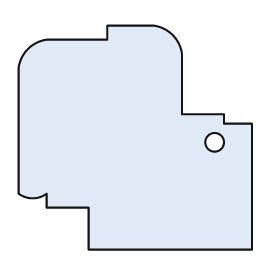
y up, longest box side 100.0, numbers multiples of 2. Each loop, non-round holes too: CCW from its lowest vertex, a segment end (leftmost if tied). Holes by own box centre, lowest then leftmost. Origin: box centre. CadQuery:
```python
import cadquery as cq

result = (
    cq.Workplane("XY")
    .moveTo(-20.0, -48.0)
    .lineTo(50.0, -48.0)
    .lineTo(50.0, 6.0)
    .lineTo(38.0, 6.0)
    .lineTo(38.0, 10.0)
    .lineTo(20.0, 10.0)
    .lineTo(20.0, 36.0)
    .threePointArc((16.0, 44.0), (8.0, 48.0))
    .lineTo(-12.0, 48.0)
    .lineTo(-12.0, 42.0)
    .lineTo(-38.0, 42.0)
    .threePointArc((-46.0, 38.0), (-50.0, 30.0))
    .lineTo(-50.0, -24.0)
    .threePointArc((-44.0, -26.0), (-38.0, -24.0))
    .lineTo(-38.0, -30.0)
    .lineTo(-20.0, -30.0)
    .close()
    .moveTo(34.0, -2.0)
    .circle(4.0)
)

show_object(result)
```